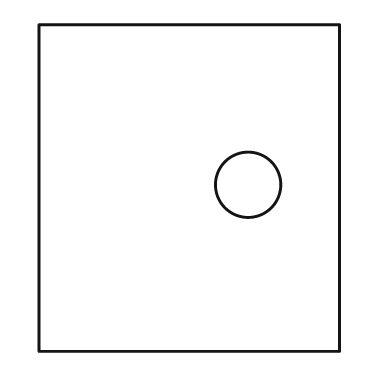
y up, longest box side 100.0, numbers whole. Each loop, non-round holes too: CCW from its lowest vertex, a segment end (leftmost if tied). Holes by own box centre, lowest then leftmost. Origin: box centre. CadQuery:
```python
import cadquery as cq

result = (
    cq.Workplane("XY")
    .moveTo(-46.0, -50.0)
    .lineTo(46.0, -50.0)
    .lineTo(46.0, 50.0)
    .lineTo(-46.0, 50.0)
    .close()
    .moveTo(18.0, 1.0)
    .circle(10.0)
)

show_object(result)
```